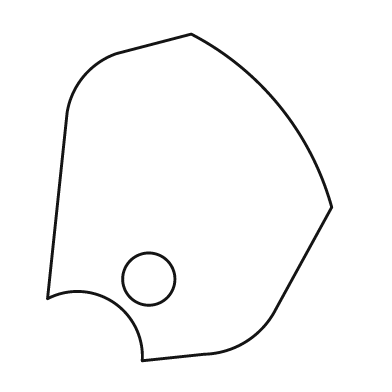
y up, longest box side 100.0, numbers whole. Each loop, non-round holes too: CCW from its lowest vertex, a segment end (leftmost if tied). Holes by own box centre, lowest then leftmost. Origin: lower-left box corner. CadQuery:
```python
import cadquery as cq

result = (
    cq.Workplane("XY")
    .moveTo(29.0, 0.0)
    .lineTo(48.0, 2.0)
    .threePointArc((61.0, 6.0), (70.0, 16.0))
    .lineTo(87.0, 47.0)
    .threePointArc((71.0, 78.0), (44.0, 100.0))
    .lineTo(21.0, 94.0)
    .threePointArc((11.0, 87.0), (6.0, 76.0))
    .lineTo(0.0, 19.0)
    .threePointArc((20.0, 18.0), (29.0, 0.0))
    .close()
    .moveTo(31.0, 25.0)
    .circle(8.0)
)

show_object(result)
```